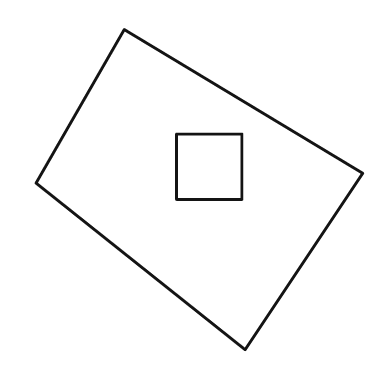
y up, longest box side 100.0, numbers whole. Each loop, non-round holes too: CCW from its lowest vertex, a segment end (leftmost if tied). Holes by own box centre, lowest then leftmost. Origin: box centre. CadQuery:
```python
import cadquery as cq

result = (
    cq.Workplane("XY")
    .moveTo(14.0, -49.0)
    .lineTo(50.0, 5.0)
    .lineTo(-23.0, 49.0)
    .lineTo(-50.0, 2.0)
    .close()
    .moveTo(-7.0, -3.0)
    .lineTo(13.0, -3.0)
    .lineTo(13.0, 17.0)
    .lineTo(-7.0, 17.0)
    .close()
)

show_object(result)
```